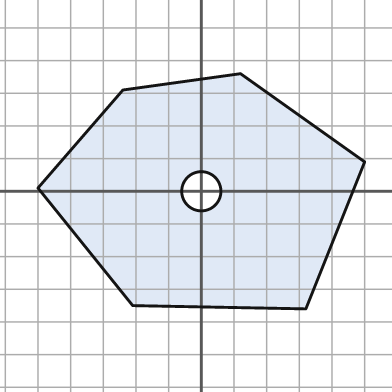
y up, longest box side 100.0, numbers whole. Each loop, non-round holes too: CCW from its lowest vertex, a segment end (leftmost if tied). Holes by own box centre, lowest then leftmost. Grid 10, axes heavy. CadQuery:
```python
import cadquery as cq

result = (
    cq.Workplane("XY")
    .moveTo(32.0, -36.0)
    .lineTo(50.0, 9.0)
    .lineTo(12.0, 36.0)
    .lineTo(-24.0, 31.0)
    .lineTo(-50.0, 1.0)
    .lineTo(-21.0, -35.0)
    .close()
    .moveTo(0.0, 0.0)
    .circle(6.0)
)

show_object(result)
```